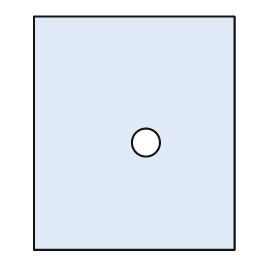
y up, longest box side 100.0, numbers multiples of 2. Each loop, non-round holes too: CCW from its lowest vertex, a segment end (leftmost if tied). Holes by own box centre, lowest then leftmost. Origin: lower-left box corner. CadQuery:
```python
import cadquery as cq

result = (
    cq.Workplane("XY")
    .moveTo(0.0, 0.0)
    .lineTo(86.0, 0.0)
    .lineTo(86.0, 100.0)
    .lineTo(0.0, 100.0)
    .close()
    .moveTo(48.0, 46.0)
    .circle(6.0)
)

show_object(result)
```